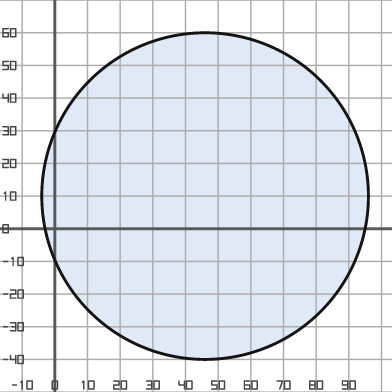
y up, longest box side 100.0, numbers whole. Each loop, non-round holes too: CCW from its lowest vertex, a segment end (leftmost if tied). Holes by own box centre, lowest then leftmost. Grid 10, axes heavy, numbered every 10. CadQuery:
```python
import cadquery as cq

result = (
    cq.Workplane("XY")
    .moveTo(46.0, 10.0)
    .circle(50.0)
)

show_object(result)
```